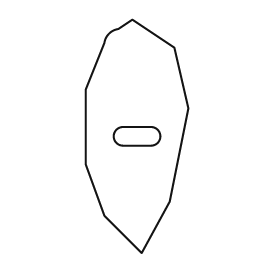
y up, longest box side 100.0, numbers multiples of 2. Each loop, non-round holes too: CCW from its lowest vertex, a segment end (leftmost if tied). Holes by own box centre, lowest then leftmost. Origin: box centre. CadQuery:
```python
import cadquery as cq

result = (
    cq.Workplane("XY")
    .moveTo(2.0, -50.0)
    .lineTo(14.0, -28.0)
    .lineTo(22.0, 12.0)
    .lineTo(16.0, 38.0)
    .lineTo(-2.0, 50.0)
    .lineTo(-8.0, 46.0)
    .threePointArc((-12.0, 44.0), (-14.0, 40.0))
    .lineTo(-22.0, 20.0)
    .lineTo(-22.0, -12.0)
    .lineTo(-14.0, -34.0)
    .close()
    .moveTo(-6.0, -4.0)
    .lineTo(6.0, -4.0)
    .threePointArc((10.0, 0.0), (6.0, 4.0))
    .lineTo(-6.0, 4.0)
    .threePointArc((-10.0, 0.0), (-6.0, -4.0))
    .close()
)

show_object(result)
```